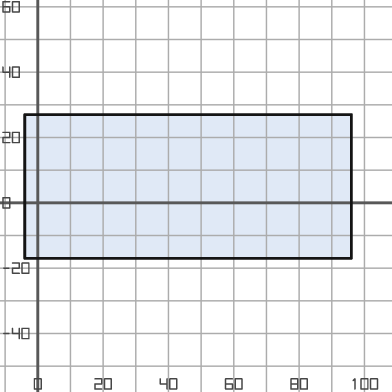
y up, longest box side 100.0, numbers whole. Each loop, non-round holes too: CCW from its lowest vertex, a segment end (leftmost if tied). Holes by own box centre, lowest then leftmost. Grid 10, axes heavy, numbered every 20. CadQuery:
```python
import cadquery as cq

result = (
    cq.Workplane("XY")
    .moveTo(-4.0, -17.0)
    .lineTo(96.0, -17.0)
    .lineTo(96.0, 27.0)
    .lineTo(-4.0, 27.0)
    .close()
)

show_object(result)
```